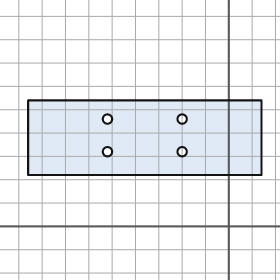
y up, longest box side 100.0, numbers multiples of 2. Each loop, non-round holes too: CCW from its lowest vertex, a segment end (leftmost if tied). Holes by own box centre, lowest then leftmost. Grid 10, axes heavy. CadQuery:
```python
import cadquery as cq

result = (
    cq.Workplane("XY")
    .moveTo(-86.0, 22.0)
    .lineTo(14.0, 22.0)
    .lineTo(14.0, 54.0)
    .lineTo(-86.0, 54.0)
    .close()
    .moveTo(-52.0, 32.0)
    .circle(2.0)
    .moveTo(-20.0, 32.0)
    .circle(2.0)
    .moveTo(-52.0, 46.0)
    .circle(2.0)
    .moveTo(-20.0, 46.0)
    .circle(2.0)
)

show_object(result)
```